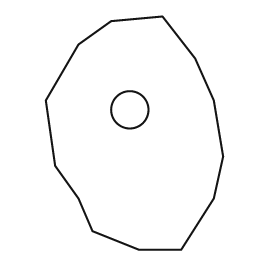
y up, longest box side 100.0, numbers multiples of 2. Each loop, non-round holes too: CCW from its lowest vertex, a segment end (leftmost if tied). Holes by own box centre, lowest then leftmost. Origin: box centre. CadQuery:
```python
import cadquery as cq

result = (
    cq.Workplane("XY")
    .moveTo(2.0, -50.0)
    .lineTo(20.0, -50.0)
    .lineTo(34.0, -28.0)
    .lineTo(38.0, -10.0)
    .lineTo(34.0, 14.0)
    .lineTo(26.0, 32.0)
    .lineTo(12.0, 50.0)
    .lineTo(-10.0, 48.0)
    .lineTo(-24.0, 38.0)
    .lineTo(-38.0, 14.0)
    .lineTo(-34.0, -14.0)
    .lineTo(-24.0, -28.0)
    .lineTo(-18.0, -42.0)
    .close()
    .moveTo(-2.0, 10.0)
    .circle(8.0)
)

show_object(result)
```